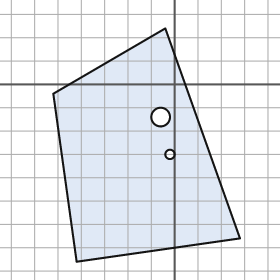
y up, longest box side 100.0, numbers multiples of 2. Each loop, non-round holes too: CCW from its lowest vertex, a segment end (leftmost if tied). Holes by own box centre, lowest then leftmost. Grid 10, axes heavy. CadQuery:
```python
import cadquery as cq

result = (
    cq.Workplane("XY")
    .moveTo(-42.0, -76.0)
    .lineTo(28.0, -66.0)
    .lineTo(-4.0, 24.0)
    .lineTo(-52.0, -4.0)
    .close()
    .moveTo(-2.0, -30.0)
    .circle(2.0)
    .moveTo(-6.0, -14.0)
    .circle(4.0)
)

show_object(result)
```